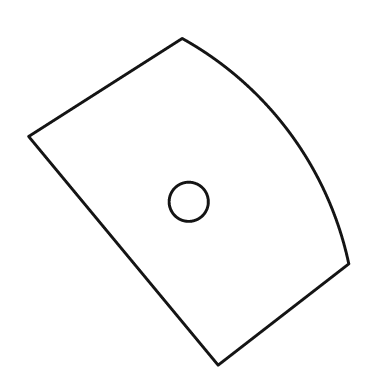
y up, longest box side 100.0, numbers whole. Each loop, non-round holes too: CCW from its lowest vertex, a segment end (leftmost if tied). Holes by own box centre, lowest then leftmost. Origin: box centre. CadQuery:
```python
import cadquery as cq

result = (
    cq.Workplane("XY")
    .moveTo(9.0, -50.0)
    .lineTo(49.0, -19.0)
    .threePointArc((31.0, 21.0), (-2.0, 50.0))
    .lineTo(-49.0, 20.0)
    .close()
    .moveTo(0.0, 0.0)
    .circle(6.0)
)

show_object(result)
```